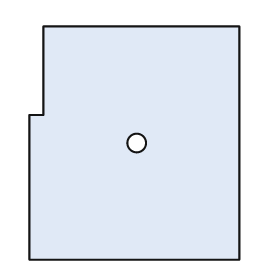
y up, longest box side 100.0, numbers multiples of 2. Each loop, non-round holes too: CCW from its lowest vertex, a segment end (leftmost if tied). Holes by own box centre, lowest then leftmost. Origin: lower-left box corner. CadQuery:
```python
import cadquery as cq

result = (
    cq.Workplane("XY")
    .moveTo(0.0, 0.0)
    .lineTo(90.0, 0.0)
    .lineTo(90.0, 100.0)
    .lineTo(6.0, 100.0)
    .lineTo(6.0, 62.0)
    .lineTo(0.0, 62.0)
    .close()
    .moveTo(46.0, 50.0)
    .circle(4.0)
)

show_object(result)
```